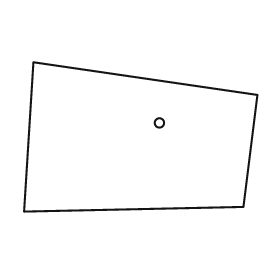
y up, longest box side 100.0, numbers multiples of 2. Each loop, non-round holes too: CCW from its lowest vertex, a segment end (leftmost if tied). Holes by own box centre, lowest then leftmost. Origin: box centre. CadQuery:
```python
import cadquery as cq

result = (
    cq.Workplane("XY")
    .moveTo(-50.0, -32.0)
    .lineTo(44.0, -30.0)
    .lineTo(50.0, 18.0)
    .lineTo(-46.0, 32.0)
    .close()
    .moveTo(8.0, 6.0)
    .circle(2.0)
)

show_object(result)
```